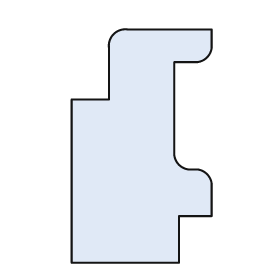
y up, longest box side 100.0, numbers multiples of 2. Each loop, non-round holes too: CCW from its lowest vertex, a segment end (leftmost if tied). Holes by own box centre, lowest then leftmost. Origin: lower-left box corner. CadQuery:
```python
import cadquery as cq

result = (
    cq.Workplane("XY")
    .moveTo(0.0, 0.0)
    .lineTo(46.0, 0.0)
    .lineTo(46.0, 20.0)
    .lineTo(60.0, 20.0)
    .lineTo(60.0, 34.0)
    .threePointArc((58.0, 38.0), (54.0, 40.0))
    .lineTo(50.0, 40.0)
    .threePointArc((46.0, 42.0), (44.0, 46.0))
    .lineTo(44.0, 86.0)
    .lineTo(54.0, 86.0)
    .threePointArc((58.0, 88.0), (60.0, 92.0))
    .lineTo(60.0, 100.0)
    .lineTo(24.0, 100.0)
    .threePointArc((18.0, 98.0), (16.0, 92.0))
    .lineTo(16.0, 70.0)
    .lineTo(0.0, 70.0)
    .close()
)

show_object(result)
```